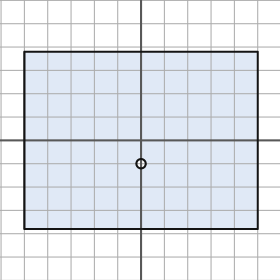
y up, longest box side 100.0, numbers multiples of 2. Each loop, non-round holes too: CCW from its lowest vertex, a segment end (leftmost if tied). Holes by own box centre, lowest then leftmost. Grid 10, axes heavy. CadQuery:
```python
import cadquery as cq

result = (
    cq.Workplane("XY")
    .moveTo(-50.0, -38.0)
    .lineTo(50.0, -38.0)
    .lineTo(50.0, 38.0)
    .lineTo(-50.0, 38.0)
    .close()
    .moveTo(0.0, -10.0)
    .circle(2.0)
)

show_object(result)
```